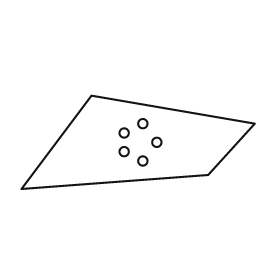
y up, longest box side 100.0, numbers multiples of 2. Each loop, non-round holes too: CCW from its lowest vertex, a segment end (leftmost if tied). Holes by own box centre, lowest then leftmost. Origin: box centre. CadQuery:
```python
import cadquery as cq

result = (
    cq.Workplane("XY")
    .moveTo(-50.0, -20.0)
    .lineTo(30.0, -14.0)
    .lineTo(50.0, 8.0)
    .lineTo(-20.0, 20.0)
    .close()
    .moveTo(2.0, -8.0)
    .circle(2.0)
    .moveTo(-6.0, -4.0)
    .circle(2.0)
    .moveTo(8.0, 0.0)
    .circle(2.0)
    .moveTo(-6.0, 4.0)
    .circle(2.0)
    .moveTo(2.0, 8.0)
    .circle(2.0)
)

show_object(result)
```